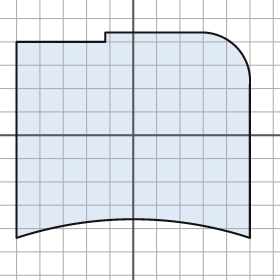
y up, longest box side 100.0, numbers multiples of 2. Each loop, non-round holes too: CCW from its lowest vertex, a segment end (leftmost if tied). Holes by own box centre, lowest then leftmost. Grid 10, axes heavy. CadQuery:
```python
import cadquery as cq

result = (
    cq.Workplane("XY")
    .moveTo(-50.0, -44.0)
    .threePointArc((0.0, -36.0), (50.0, -44.0))
    .lineTo(50.0, 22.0)
    .threePointArc((44.0, 38.0), (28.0, 44.0))
    .lineTo(-12.0, 44.0)
    .lineTo(-12.0, 40.0)
    .lineTo(-50.0, 40.0)
    .close()
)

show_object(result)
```